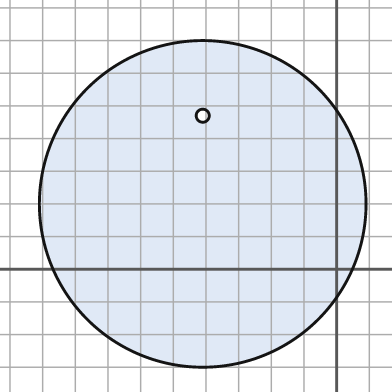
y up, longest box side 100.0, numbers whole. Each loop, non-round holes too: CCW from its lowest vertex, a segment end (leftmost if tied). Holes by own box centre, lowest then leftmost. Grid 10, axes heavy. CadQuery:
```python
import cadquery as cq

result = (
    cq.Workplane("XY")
    .moveTo(-41.0, 20.0)
    .circle(50.0)
    .moveTo(-41.0, 47.0)
    .circle(2.0)
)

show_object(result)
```